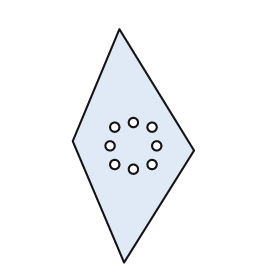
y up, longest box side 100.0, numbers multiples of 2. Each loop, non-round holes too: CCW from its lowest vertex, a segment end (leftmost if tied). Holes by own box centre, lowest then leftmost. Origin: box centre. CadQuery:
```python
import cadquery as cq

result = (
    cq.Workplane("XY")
    .moveTo(-4.0, -50.0)
    .lineTo(26.0, -2.0)
    .lineTo(-6.0, 50.0)
    .lineTo(-26.0, 2.0)
    .close()
    .moveTo(0.0, -10.0)
    .circle(2.0)
    .moveTo(-8.0, -8.0)
    .circle(2.0)
    .moveTo(8.0, -8.0)
    .circle(2.0)
    .moveTo(-10.0, 0.0)
    .circle(2.0)
    .moveTo(10.0, 0.0)
    .circle(2.0)
    .moveTo(-8.0, 8.0)
    .circle(2.0)
    .moveTo(8.0, 8.0)
    .circle(2.0)
    .moveTo(0.0, 10.0)
    .circle(2.0)
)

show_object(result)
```